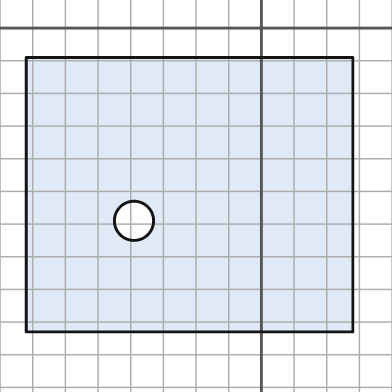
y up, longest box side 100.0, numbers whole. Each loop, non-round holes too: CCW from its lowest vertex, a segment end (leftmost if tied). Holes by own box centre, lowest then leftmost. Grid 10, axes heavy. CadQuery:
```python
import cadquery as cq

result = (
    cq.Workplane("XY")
    .moveTo(-72.0, -93.0)
    .lineTo(28.0, -93.0)
    .lineTo(28.0, -9.0)
    .lineTo(-72.0, -9.0)
    .close()
    .moveTo(-39.0, -59.0)
    .circle(6.0)
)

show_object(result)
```